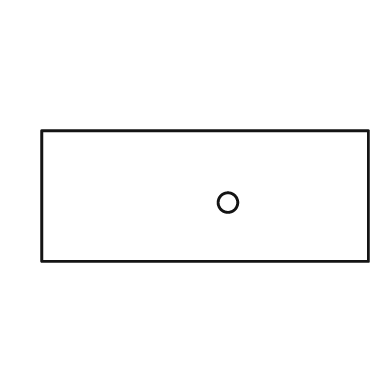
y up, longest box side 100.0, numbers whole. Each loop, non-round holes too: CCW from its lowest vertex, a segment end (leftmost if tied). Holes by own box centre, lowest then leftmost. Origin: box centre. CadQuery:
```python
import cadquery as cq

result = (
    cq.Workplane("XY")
    .moveTo(-50.0, -20.0)
    .lineTo(50.0, -20.0)
    .lineTo(50.0, 20.0)
    .lineTo(-50.0, 20.0)
    .close()
    .moveTo(7.0, -2.0)
    .circle(3.0)
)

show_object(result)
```